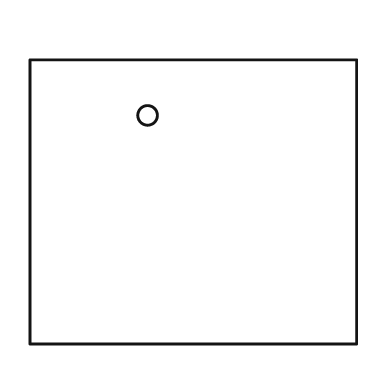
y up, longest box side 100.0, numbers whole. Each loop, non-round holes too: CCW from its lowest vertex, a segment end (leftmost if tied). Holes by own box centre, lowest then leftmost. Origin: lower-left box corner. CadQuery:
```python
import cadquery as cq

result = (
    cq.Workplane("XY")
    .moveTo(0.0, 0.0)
    .lineTo(100.0, 0.0)
    .lineTo(100.0, 87.0)
    .lineTo(0.0, 87.0)
    .close()
    .moveTo(36.0, 70.0)
    .circle(3.0)
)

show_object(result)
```